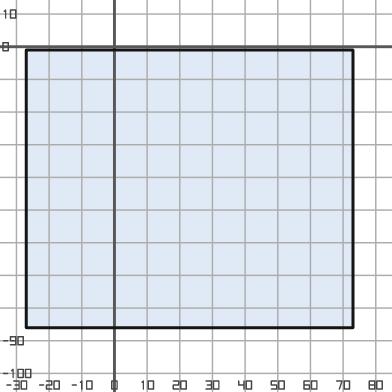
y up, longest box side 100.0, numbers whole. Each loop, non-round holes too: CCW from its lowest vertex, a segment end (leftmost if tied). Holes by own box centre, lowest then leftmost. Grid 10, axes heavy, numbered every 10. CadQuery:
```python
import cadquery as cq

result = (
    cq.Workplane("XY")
    .moveTo(-27.0, -86.0)
    .lineTo(73.0, -86.0)
    .lineTo(73.0, -1.0)
    .lineTo(-27.0, -1.0)
    .close()
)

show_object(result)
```